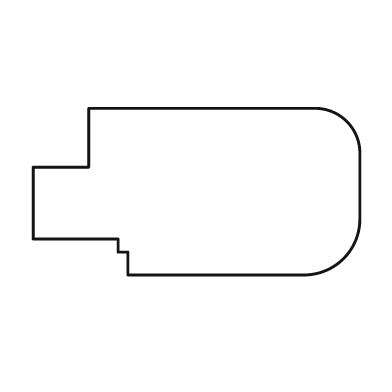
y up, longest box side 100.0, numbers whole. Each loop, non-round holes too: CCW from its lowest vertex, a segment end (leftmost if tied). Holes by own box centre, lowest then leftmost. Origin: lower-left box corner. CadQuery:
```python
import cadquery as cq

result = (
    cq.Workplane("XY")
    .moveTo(29.0, 0.0)
    .lineTo(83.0, 0.0)
    .threePointArc((95.0, 5.0), (100.0, 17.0))
    .lineTo(100.0, 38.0)
    .threePointArc((96.0, 47.0), (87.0, 51.0))
    .lineTo(17.0, 51.0)
    .lineTo(17.0, 33.0)
    .lineTo(0.0, 33.0)
    .lineTo(0.0, 11.0)
    .lineTo(26.0, 11.0)
    .lineTo(26.0, 7.0)
    .lineTo(29.0, 7.0)
    .close()
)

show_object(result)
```